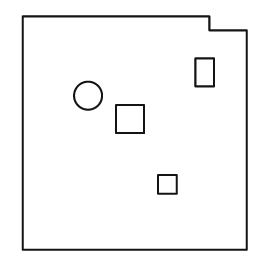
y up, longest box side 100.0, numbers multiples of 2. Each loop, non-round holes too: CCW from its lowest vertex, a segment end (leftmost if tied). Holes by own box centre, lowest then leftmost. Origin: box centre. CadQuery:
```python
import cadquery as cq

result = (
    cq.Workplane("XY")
    .moveTo(-48.0, -50.0)
    .lineTo(48.0, -50.0)
    .lineTo(48.0, 44.0)
    .lineTo(32.0, 44.0)
    .lineTo(32.0, 50.0)
    .lineTo(-48.0, 50.0)
    .close()
    .moveTo(10.0, -26.0)
    .lineTo(18.0, -26.0)
    .lineTo(18.0, -18.0)
    .lineTo(10.0, -18.0)
    .close()
    .moveTo(-8.0, 0.0)
    .lineTo(4.0, 0.0)
    .lineTo(4.0, 12.0)
    .lineTo(-8.0, 12.0)
    .close()
    .moveTo(-20.0, 16.0)
    .circle(6.0)
    .moveTo(26.0, 20.0)
    .lineTo(34.0, 20.0)
    .lineTo(34.0, 32.0)
    .lineTo(26.0, 32.0)
    .close()
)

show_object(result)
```